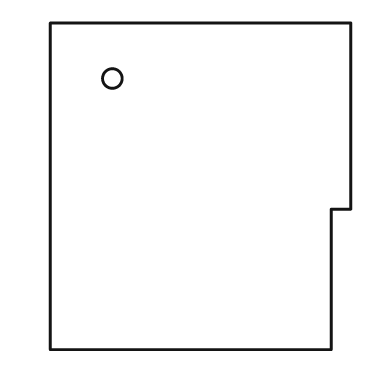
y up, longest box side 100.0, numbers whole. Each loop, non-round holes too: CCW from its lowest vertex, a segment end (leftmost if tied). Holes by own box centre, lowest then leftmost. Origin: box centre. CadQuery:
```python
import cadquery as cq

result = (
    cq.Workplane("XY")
    .moveTo(-46.0, -50.0)
    .lineTo(40.0, -50.0)
    .lineTo(40.0, -7.0)
    .lineTo(46.0, -7.0)
    .lineTo(46.0, 50.0)
    .lineTo(-46.0, 50.0)
    .close()
    .moveTo(-27.0, 33.0)
    .circle(3.0)
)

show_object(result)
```